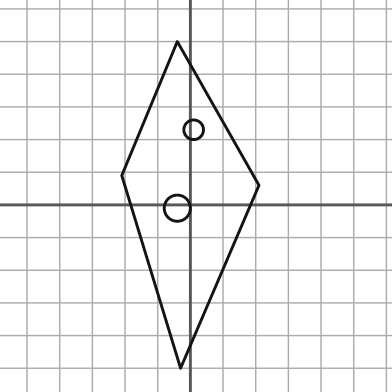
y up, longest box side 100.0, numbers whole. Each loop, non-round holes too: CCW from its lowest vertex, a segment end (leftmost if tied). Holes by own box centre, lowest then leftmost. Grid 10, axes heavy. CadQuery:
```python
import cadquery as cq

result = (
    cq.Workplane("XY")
    .moveTo(-3.0, -50.0)
    .lineTo(21.0, 6.0)
    .lineTo(-4.0, 50.0)
    .lineTo(-21.0, 9.0)
    .close()
    .moveTo(-4.0, -1.0)
    .circle(4.0)
    .moveTo(1.0, 23.0)
    .circle(3.0)
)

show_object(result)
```